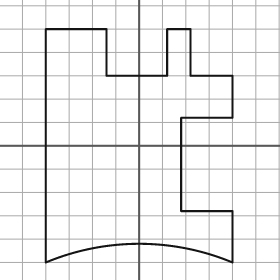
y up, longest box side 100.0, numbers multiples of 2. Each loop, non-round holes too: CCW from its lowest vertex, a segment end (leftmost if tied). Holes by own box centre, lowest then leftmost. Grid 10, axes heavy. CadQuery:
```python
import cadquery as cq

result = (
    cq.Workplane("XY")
    .moveTo(-40.0, -50.0)
    .threePointArc((0.0, -42.0), (40.0, -50.0))
    .lineTo(40.0, -28.0)
    .lineTo(18.0, -28.0)
    .lineTo(18.0, 12.0)
    .lineTo(40.0, 12.0)
    .lineTo(40.0, 30.0)
    .lineTo(22.0, 30.0)
    .lineTo(22.0, 50.0)
    .lineTo(12.0, 50.0)
    .lineTo(12.0, 30.0)
    .lineTo(-14.0, 30.0)
    .lineTo(-14.0, 50.0)
    .lineTo(-40.0, 50.0)
    .close()
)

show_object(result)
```